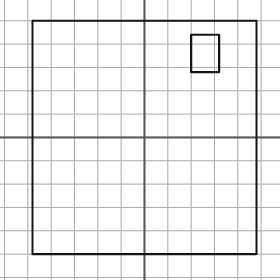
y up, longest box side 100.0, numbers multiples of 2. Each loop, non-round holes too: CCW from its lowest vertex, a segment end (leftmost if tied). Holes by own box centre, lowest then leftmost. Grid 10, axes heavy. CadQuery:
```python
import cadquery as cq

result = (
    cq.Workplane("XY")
    .moveTo(-48.0, -50.0)
    .lineTo(48.0, -50.0)
    .lineTo(48.0, 50.0)
    .lineTo(-48.0, 50.0)
    .close()
    .moveTo(20.0, 28.0)
    .lineTo(32.0, 28.0)
    .lineTo(32.0, 44.0)
    .lineTo(20.0, 44.0)
    .close()
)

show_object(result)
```